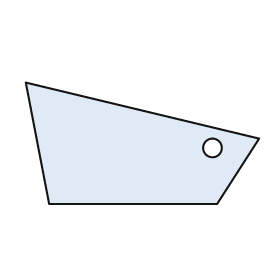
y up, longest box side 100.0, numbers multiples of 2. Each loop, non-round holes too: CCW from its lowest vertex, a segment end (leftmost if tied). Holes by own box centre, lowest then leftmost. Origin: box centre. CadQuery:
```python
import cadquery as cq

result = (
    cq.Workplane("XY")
    .moveTo(-40.0, -26.0)
    .lineTo(32.0, -26.0)
    .lineTo(50.0, 2.0)
    .lineTo(-50.0, 26.0)
    .close()
    .moveTo(30.0, -2.0)
    .circle(4.0)
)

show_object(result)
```